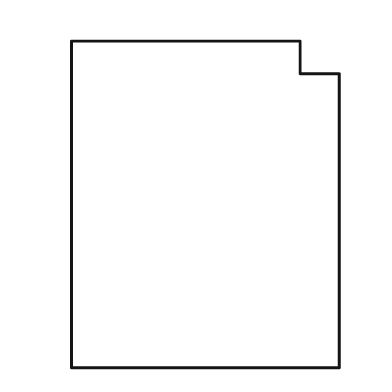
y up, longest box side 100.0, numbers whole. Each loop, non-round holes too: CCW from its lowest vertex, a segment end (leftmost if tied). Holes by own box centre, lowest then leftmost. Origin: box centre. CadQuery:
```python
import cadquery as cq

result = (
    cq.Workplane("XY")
    .moveTo(-41.0, -50.0)
    .lineTo(41.0, -50.0)
    .lineTo(41.0, 40.0)
    .lineTo(29.0, 40.0)
    .lineTo(29.0, 50.0)
    .lineTo(-41.0, 50.0)
    .close()
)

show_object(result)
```